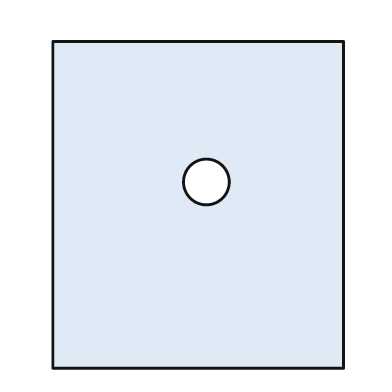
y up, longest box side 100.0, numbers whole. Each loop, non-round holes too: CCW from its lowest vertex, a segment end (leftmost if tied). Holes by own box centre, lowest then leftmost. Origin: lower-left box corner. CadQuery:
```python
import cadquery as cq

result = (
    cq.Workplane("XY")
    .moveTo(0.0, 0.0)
    .lineTo(89.0, 0.0)
    .lineTo(89.0, 100.0)
    .lineTo(0.0, 100.0)
    .close()
    .moveTo(47.0, 57.0)
    .circle(7.0)
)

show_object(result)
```